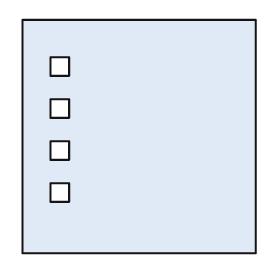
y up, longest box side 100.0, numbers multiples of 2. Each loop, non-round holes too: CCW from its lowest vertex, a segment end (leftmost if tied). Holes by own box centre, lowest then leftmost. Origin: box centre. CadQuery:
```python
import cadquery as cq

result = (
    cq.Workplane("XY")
    .moveTo(-50.0, -50.0)
    .lineTo(50.0, -50.0)
    .lineTo(50.0, 50.0)
    .lineTo(-50.0, 50.0)
    .close()
    .moveTo(-38.0, -28.0)
    .lineTo(-30.0, -28.0)
    .lineTo(-30.0, -20.0)
    .lineTo(-38.0, -20.0)
    .close()
    .moveTo(-38.0, -10.0)
    .lineTo(-30.0, -10.0)
    .lineTo(-30.0, -2.0)
    .lineTo(-38.0, -2.0)
    .close()
    .moveTo(-38.0, 8.0)
    .lineTo(-30.0, 8.0)
    .lineTo(-30.0, 16.0)
    .lineTo(-38.0, 16.0)
    .close()
    .moveTo(-38.0, 26.0)
    .lineTo(-30.0, 26.0)
    .lineTo(-30.0, 34.0)
    .lineTo(-38.0, 34.0)
    .close()
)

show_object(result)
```